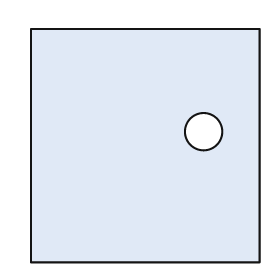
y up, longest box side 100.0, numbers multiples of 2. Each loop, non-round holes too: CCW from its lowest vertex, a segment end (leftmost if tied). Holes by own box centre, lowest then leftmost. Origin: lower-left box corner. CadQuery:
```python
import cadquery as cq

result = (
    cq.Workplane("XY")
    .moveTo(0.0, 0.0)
    .lineTo(98.0, 0.0)
    .lineTo(98.0, 100.0)
    .lineTo(0.0, 100.0)
    .close()
    .moveTo(74.0, 56.0)
    .circle(8.0)
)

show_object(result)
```